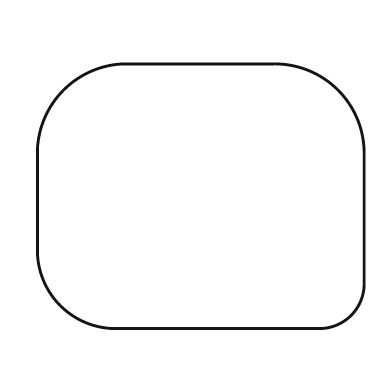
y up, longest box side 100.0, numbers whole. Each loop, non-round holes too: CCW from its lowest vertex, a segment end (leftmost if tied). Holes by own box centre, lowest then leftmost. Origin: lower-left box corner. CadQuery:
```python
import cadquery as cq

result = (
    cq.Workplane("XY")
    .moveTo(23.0, 0.0)
    .lineTo(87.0, 0.0)
    .threePointArc((96.0, 4.0), (100.0, 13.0))
    .lineTo(100.0, 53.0)
    .threePointArc((92.0, 73.0), (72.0, 81.0))
    .lineTo(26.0, 81.0)
    .threePointArc((8.0, 73.0), (0.0, 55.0))
    .lineTo(0.0, 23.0)
    .threePointArc((7.0, 7.0), (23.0, 0.0))
    .close()
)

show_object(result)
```